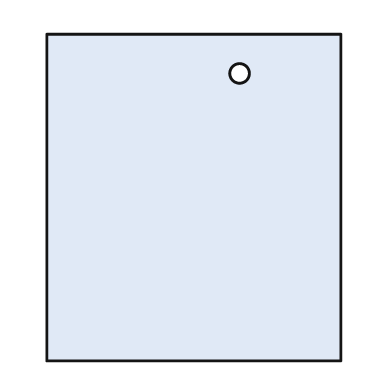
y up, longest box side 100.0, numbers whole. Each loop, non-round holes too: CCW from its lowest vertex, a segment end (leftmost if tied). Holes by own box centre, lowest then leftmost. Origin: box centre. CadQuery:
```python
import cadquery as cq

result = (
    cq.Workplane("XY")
    .moveTo(-45.0, -50.0)
    .lineTo(45.0, -50.0)
    .lineTo(45.0, 50.0)
    .lineTo(-45.0, 50.0)
    .close()
    .moveTo(14.0, 38.0)
    .circle(3.0)
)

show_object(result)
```